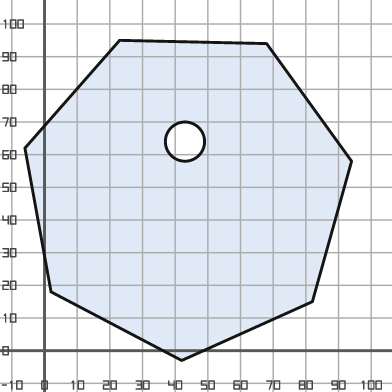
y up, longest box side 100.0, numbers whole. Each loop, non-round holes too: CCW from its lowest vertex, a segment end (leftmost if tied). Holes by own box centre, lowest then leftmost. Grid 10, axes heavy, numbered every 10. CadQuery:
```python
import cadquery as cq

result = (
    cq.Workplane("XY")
    .moveTo(42.0, -3.0)
    .lineTo(82.0, 15.0)
    .lineTo(94.0, 58.0)
    .lineTo(68.0, 94.0)
    .lineTo(23.0, 95.0)
    .lineTo(-6.0, 62.0)
    .lineTo(2.0, 18.0)
    .close()
    .moveTo(43.0, 64.0)
    .circle(6.0)
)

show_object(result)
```